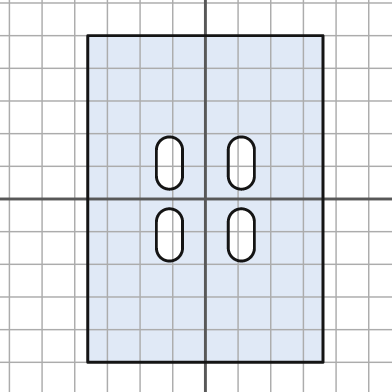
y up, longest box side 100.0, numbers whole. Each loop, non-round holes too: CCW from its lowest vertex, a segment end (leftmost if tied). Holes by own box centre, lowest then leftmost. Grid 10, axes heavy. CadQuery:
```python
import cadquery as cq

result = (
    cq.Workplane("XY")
    .moveTo(-36.0, -50.0)
    .lineTo(36.0, -50.0)
    .lineTo(36.0, 50.0)
    .lineTo(-36.0, 50.0)
    .close()
    .moveTo(-15.0, -15.0)
    .threePointArc((-11.0, -19.0), (-7.0, -15.0))
    .lineTo(-7.0, -7.0)
    .threePointArc((-11.0, -3.0), (-15.0, -7.0))
    .close()
    .moveTo(7.0, -15.0)
    .threePointArc((11.0, -19.0), (15.0, -15.0))
    .lineTo(15.0, -7.0)
    .threePointArc((11.0, -3.0), (7.0, -7.0))
    .close()
    .moveTo(-15.0, 7.0)
    .threePointArc((-11.0, 3.0), (-7.0, 7.0))
    .lineTo(-7.0, 15.0)
    .threePointArc((-11.0, 19.0), (-15.0, 15.0))
    .close()
    .moveTo(7.0, 7.0)
    .threePointArc((11.0, 3.0), (15.0, 7.0))
    .lineTo(15.0, 15.0)
    .threePointArc((11.0, 19.0), (7.0, 15.0))
    .close()
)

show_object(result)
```